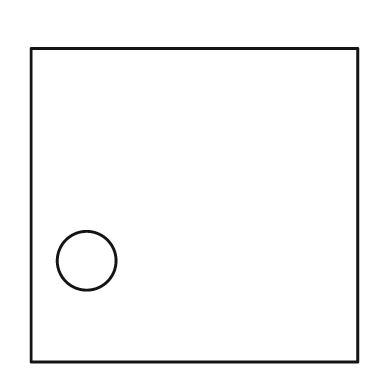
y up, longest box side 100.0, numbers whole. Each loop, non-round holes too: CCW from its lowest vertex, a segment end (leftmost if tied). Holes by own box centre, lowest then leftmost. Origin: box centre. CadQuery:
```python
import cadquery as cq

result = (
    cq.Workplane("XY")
    .moveTo(-50.0, -48.0)
    .lineTo(50.0, -48.0)
    .lineTo(50.0, 48.0)
    .lineTo(-50.0, 48.0)
    .close()
    .moveTo(-33.0, -17.0)
    .circle(9.0)
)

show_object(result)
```